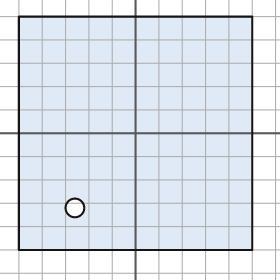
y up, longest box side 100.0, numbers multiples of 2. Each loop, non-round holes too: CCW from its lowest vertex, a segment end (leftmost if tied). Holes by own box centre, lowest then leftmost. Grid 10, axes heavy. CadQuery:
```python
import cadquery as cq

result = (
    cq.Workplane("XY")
    .moveTo(-50.0, -50.0)
    .lineTo(50.0, -50.0)
    .lineTo(50.0, 50.0)
    .lineTo(-50.0, 50.0)
    .close()
    .moveTo(-26.0, -32.0)
    .circle(4.0)
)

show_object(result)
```